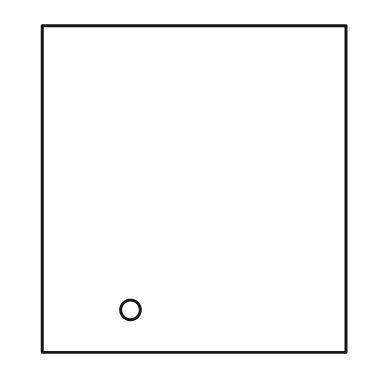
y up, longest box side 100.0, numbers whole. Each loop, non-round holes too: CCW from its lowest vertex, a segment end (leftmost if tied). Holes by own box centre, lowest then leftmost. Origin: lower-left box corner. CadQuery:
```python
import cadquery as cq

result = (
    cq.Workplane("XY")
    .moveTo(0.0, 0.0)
    .lineTo(93.0, 0.0)
    .lineTo(93.0, 100.0)
    .lineTo(0.0, 100.0)
    .close()
    .moveTo(27.0, 13.0)
    .circle(3.0)
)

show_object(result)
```